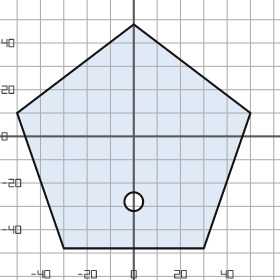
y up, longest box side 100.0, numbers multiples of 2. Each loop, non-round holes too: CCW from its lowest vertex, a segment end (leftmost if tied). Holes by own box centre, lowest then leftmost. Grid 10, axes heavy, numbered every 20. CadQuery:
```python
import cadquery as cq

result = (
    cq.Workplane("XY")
    .moveTo(-30.0, -48.0)
    .lineTo(30.0, -48.0)
    .lineTo(50.0, 10.0)
    .lineTo(0.0, 48.0)
    .lineTo(-50.0, 10.0)
    .close()
    .moveTo(0.0, -28.0)
    .circle(4.0)
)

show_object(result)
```